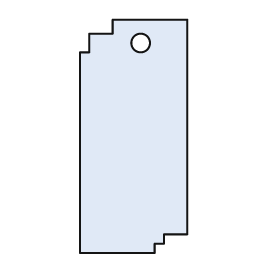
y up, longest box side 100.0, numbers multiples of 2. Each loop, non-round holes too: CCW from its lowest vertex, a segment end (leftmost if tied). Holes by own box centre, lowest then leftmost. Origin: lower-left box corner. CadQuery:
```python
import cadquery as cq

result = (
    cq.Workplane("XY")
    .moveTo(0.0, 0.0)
    .lineTo(32.0, 0.0)
    .lineTo(32.0, 4.0)
    .lineTo(36.0, 4.0)
    .lineTo(36.0, 8.0)
    .lineTo(46.0, 8.0)
    .lineTo(46.0, 100.0)
    .lineTo(14.0, 100.0)
    .lineTo(14.0, 94.0)
    .lineTo(4.0, 94.0)
    .lineTo(4.0, 86.0)
    .lineTo(0.0, 86.0)
    .close()
    .moveTo(26.0, 90.0)
    .circle(4.0)
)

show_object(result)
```